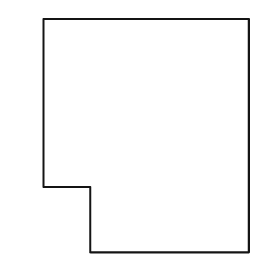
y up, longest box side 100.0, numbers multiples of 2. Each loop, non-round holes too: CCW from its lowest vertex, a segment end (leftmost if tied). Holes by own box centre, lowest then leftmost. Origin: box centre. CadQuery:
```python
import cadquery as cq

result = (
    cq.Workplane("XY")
    .moveTo(-24.0, -50.0)
    .lineTo(44.0, -50.0)
    .lineTo(44.0, 50.0)
    .lineTo(-44.0, 50.0)
    .lineTo(-44.0, -22.0)
    .lineTo(-24.0, -22.0)
    .close()
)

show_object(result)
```